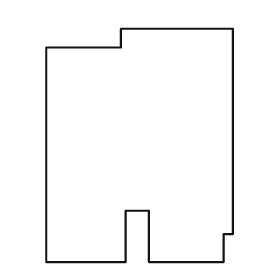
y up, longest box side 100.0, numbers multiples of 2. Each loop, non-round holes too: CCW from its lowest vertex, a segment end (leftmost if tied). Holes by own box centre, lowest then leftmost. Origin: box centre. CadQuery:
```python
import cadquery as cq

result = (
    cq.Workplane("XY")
    .moveTo(-40.0, -50.0)
    .lineTo(-6.0, -50.0)
    .lineTo(-6.0, -28.0)
    .lineTo(4.0, -28.0)
    .lineTo(4.0, -50.0)
    .lineTo(36.0, -50.0)
    .lineTo(36.0, -38.0)
    .lineTo(40.0, -38.0)
    .lineTo(40.0, 50.0)
    .lineTo(-8.0, 50.0)
    .lineTo(-8.0, 42.0)
    .lineTo(-40.0, 42.0)
    .close()
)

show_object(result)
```